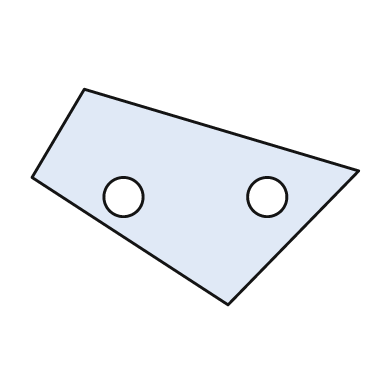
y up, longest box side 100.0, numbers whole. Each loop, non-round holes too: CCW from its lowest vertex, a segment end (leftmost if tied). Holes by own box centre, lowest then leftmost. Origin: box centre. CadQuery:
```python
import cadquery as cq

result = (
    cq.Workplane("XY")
    .moveTo(10.0, -33.0)
    .lineTo(50.0, 8.0)
    .lineTo(-34.0, 33.0)
    .lineTo(-50.0, 6.0)
    .close()
    .moveTo(-22.0, 0.0)
    .circle(6.0)
    .moveTo(22.0, 0.0)
    .circle(6.0)
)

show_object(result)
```